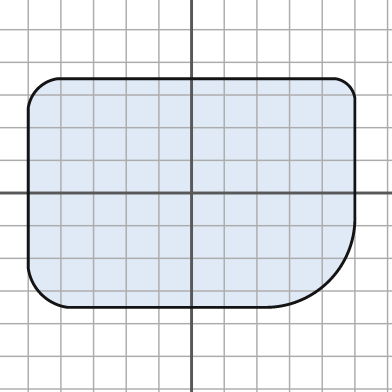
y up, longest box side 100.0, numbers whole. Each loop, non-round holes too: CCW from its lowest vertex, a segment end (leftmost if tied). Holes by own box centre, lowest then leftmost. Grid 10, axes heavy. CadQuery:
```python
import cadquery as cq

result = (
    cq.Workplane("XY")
    .moveTo(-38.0, -35.0)
    .lineTo(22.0, -35.0)
    .threePointArc((42.0, -27.0), (50.0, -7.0))
    .lineTo(50.0, 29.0)
    .threePointArc((48.0, 33.0), (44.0, 35.0))
    .lineTo(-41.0, 35.0)
    .threePointArc((-47.0, 32.0), (-50.0, 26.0))
    .lineTo(-50.0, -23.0)
    .threePointArc((-46.0, -31.0), (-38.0, -35.0))
    .close()
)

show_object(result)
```